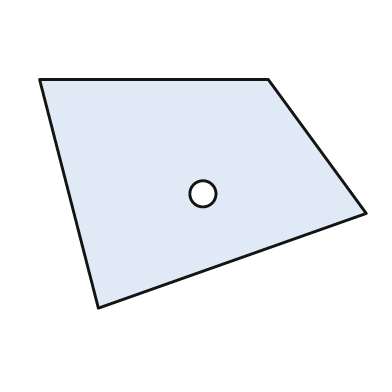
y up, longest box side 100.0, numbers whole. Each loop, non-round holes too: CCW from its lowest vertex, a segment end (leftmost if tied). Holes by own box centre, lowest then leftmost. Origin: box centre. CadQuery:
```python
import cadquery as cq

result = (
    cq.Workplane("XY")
    .moveTo(-32.0, -35.0)
    .lineTo(50.0, -6.0)
    .lineTo(20.0, 35.0)
    .lineTo(-50.0, 35.0)
    .close()
    .moveTo(0.0, 0.0)
    .circle(4.0)
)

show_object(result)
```